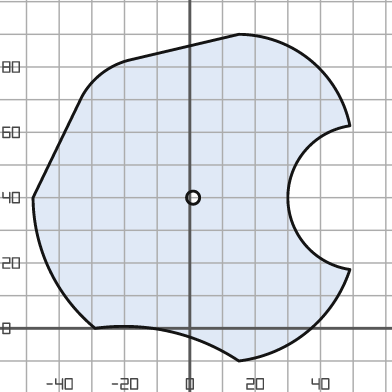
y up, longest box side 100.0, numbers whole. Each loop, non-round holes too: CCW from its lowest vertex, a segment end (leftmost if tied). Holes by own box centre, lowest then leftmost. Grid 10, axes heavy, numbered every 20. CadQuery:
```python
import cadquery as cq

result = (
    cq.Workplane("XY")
    .moveTo(15.0, -10.0)
    .threePointArc((36.0, -1.0), (49.0, 18.0))
    .threePointArc((30.0, 40.0), (49.0, 62.0))
    .threePointArc((37.0, 82.0), (15.0, 90.0))
    .lineTo(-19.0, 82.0)
    .threePointArc((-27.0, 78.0), (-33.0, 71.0))
    .lineTo(-48.0, 40.0)
    .threePointArc((-43.0, 18.0), (-29.0, 0.0))
    .threePointArc((-6.0, -1.0), (15.0, -10.0))
    .close()
    .moveTo(1.0, 40.0)
    .circle(2.0)
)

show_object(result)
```